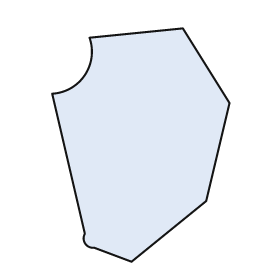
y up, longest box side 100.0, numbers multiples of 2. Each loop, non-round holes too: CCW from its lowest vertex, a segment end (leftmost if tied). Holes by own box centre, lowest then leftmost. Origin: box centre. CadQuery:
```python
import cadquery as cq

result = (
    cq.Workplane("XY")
    .moveTo(-4.0, -50.0)
    .lineTo(28.0, -24.0)
    .lineTo(38.0, 18.0)
    .lineTo(18.0, 50.0)
    .lineTo(-22.0, 46.0)
    .threePointArc((-24.0, 30.0), (-38.0, 22.0))
    .lineTo(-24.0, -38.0)
    .threePointArc((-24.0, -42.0), (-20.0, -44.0))
    .close()
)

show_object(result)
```